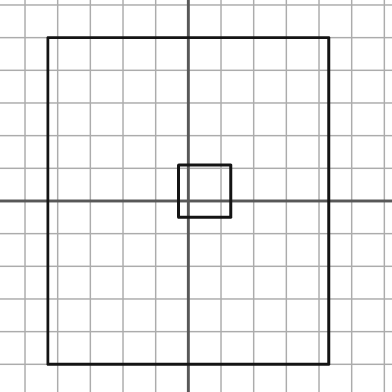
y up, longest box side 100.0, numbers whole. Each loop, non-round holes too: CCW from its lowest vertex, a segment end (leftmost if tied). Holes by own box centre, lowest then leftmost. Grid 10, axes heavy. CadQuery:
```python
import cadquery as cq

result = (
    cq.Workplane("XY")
    .moveTo(-43.0, -50.0)
    .lineTo(43.0, -50.0)
    .lineTo(43.0, 50.0)
    .lineTo(-43.0, 50.0)
    .close()
    .moveTo(-3.0, -5.0)
    .lineTo(13.0, -5.0)
    .lineTo(13.0, 11.0)
    .lineTo(-3.0, 11.0)
    .close()
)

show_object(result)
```